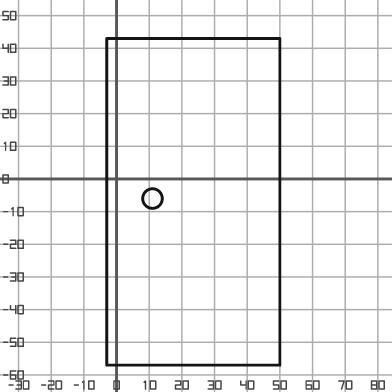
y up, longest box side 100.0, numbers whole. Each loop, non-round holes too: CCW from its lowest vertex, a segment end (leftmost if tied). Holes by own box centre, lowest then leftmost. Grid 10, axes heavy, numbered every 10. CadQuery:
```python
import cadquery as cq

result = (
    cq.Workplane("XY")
    .moveTo(-3.0, -57.0)
    .lineTo(50.0, -57.0)
    .lineTo(50.0, 43.0)
    .lineTo(-3.0, 43.0)
    .close()
    .moveTo(11.0, -6.0)
    .circle(3.0)
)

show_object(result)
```